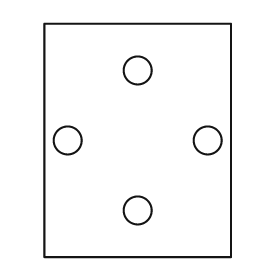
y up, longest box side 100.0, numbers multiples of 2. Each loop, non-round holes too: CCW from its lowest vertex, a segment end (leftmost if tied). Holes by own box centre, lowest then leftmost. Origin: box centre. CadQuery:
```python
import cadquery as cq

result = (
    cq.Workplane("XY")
    .moveTo(-40.0, -50.0)
    .lineTo(40.0, -50.0)
    .lineTo(40.0, 50.0)
    .lineTo(-40.0, 50.0)
    .close()
    .moveTo(0.0, -30.0)
    .circle(6.0)
    .moveTo(-30.0, 0.0)
    .circle(6.0)
    .moveTo(30.0, 0.0)
    .circle(6.0)
    .moveTo(0.0, 30.0)
    .circle(6.0)
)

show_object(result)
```